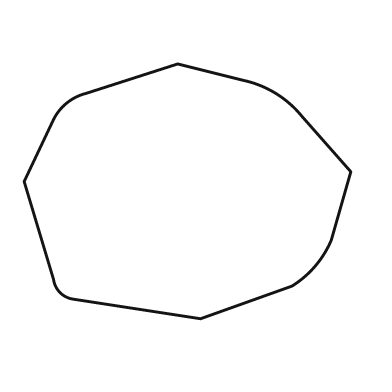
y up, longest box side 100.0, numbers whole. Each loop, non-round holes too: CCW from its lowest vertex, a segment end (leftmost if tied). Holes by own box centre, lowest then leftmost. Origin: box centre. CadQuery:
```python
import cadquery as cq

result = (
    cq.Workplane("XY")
    .moveTo(4.0, -39.0)
    .lineTo(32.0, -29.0)
    .threePointArc((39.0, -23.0), (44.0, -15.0))
    .lineTo(50.0, 6.0)
    .lineTo(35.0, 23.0)
    .threePointArc((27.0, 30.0), (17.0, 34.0))
    .lineTo(-3.0, 39.0)
    .lineTo(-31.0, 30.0)
    .threePointArc((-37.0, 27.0), (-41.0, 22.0))
    .lineTo(-50.0, 3.0)
    .lineTo(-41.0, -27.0)
    .threePointArc((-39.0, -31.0), (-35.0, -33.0))
    .close()
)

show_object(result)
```